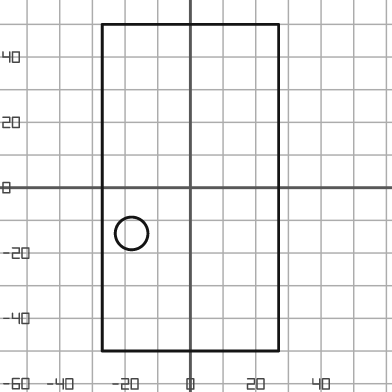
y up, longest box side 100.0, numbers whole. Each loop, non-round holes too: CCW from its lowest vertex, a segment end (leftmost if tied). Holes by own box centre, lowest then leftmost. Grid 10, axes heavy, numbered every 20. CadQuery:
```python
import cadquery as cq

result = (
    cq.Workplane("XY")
    .moveTo(-27.0, -50.0)
    .lineTo(27.0, -50.0)
    .lineTo(27.0, 50.0)
    .lineTo(-27.0, 50.0)
    .close()
    .moveTo(-18.0, -14.0)
    .circle(5.0)
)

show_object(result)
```